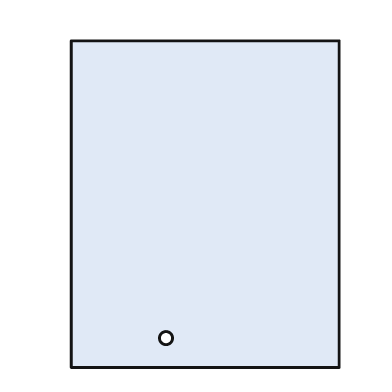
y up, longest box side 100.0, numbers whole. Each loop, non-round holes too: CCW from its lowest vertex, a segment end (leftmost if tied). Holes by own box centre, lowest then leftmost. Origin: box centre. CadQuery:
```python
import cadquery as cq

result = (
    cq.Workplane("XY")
    .moveTo(-41.0, -50.0)
    .lineTo(41.0, -50.0)
    .lineTo(41.0, 50.0)
    .lineTo(-41.0, 50.0)
    .close()
    .moveTo(-12.0, -41.0)
    .circle(2.0)
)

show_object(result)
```